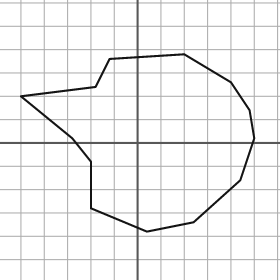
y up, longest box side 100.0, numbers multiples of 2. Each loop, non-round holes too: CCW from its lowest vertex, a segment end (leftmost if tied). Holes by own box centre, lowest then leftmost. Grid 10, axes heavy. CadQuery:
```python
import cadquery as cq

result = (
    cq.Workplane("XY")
    .moveTo(4.0, -38.0)
    .lineTo(24.0, -34.0)
    .lineTo(44.0, -16.0)
    .lineTo(50.0, 2.0)
    .lineTo(48.0, 14.0)
    .lineTo(40.0, 26.0)
    .lineTo(20.0, 38.0)
    .lineTo(-12.0, 36.0)
    .lineTo(-18.0, 24.0)
    .lineTo(-50.0, 20.0)
    .lineTo(-28.0, 2.0)
    .lineTo(-20.0, -8.0)
    .lineTo(-20.0, -28.0)
    .close()
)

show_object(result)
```